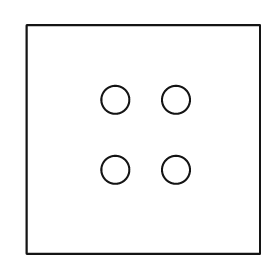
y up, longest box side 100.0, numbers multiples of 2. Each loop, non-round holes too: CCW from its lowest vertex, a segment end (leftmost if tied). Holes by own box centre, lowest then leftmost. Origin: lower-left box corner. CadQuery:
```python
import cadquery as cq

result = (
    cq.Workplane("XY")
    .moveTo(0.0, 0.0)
    .lineTo(100.0, 0.0)
    .lineTo(100.0, 98.0)
    .lineTo(0.0, 98.0)
    .close()
    .moveTo(38.0, 36.0)
    .circle(6.0)
    .moveTo(64.0, 36.0)
    .circle(6.0)
    .moveTo(38.0, 66.0)
    .circle(6.0)
    .moveTo(64.0, 66.0)
    .circle(6.0)
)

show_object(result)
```